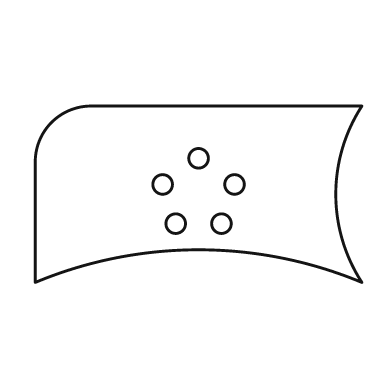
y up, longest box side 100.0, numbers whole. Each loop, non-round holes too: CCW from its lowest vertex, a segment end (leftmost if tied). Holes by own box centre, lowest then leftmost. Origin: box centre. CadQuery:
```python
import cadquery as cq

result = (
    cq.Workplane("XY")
    .moveTo(-50.0, -27.0)
    .threePointArc((0.0, -17.0), (50.0, -27.0))
    .threePointArc((42.0, 0.0), (50.0, 27.0))
    .lineTo(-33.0, 27.0)
    .threePointArc((-45.0, 22.0), (-50.0, 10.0))
    .close()
    .moveTo(-7.0, -9.0)
    .circle(3.0)
    .moveTo(7.0, -9.0)
    .circle(3.0)
    .moveTo(-11.0, 3.0)
    .circle(3.0)
    .moveTo(11.0, 3.0)
    .circle(3.0)
    .moveTo(0.0, 11.0)
    .circle(3.0)
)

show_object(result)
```